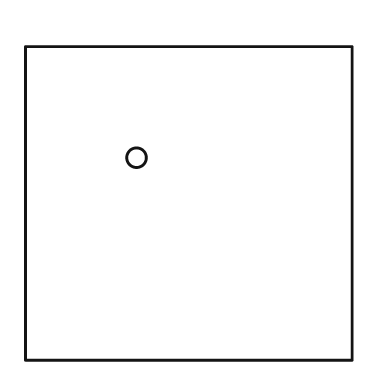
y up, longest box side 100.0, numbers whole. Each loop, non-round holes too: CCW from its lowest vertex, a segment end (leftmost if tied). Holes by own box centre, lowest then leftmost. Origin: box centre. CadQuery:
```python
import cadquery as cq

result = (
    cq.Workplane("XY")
    .moveTo(-50.0, -48.0)
    .lineTo(50.0, -48.0)
    .lineTo(50.0, 48.0)
    .lineTo(-50.0, 48.0)
    .close()
    .moveTo(-16.0, 14.0)
    .circle(3.0)
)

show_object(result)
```